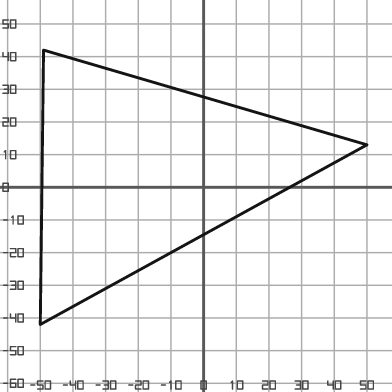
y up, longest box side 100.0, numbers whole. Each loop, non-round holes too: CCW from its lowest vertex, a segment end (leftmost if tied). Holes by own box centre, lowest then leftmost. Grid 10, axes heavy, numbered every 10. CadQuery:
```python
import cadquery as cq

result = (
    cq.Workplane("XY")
    .moveTo(-50.0, -42.0)
    .lineTo(50.0, 13.0)
    .lineTo(-49.0, 42.0)
    .close()
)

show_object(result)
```